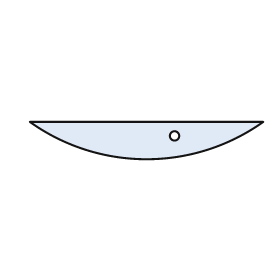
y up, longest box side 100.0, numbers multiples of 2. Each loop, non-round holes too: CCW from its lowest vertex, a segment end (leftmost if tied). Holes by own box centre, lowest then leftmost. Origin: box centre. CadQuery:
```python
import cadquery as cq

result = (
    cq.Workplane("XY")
    .moveTo(-50.0, 8.0)
    .threePointArc((0.0, -8.0), (50.0, 8.0))
    .close()
    .moveTo(12.0, 2.0)
    .circle(2.0)
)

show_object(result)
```